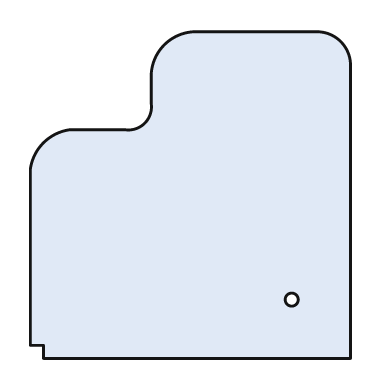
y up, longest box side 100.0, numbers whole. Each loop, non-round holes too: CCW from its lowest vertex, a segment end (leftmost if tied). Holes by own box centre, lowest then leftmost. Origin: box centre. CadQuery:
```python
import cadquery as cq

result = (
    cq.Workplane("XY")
    .moveTo(-45.0, -50.0)
    .lineTo(49.0, -50.0)
    .lineTo(49.0, 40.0)
    .threePointArc((46.0, 47.0), (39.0, 50.0))
    .lineTo(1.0, 50.0)
    .threePointArc((-8.0, 46.0), (-12.0, 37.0))
    .lineTo(-12.0, 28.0)
    .threePointArc((-14.0, 22.0), (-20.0, 20.0))
    .lineTo(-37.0, 20.0)
    .threePointArc((-45.0, 16.0), (-49.0, 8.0))
    .lineTo(-49.0, -46.0)
    .lineTo(-45.0, -46.0)
    .close()
    .moveTo(31.0, -32.0)
    .circle(2.0)
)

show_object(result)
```